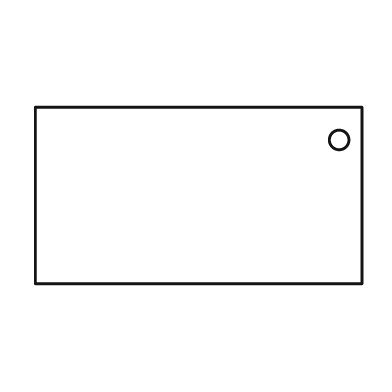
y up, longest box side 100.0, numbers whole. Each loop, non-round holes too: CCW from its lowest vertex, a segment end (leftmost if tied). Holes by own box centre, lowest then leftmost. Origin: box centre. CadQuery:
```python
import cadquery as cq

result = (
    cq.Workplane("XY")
    .moveTo(-50.0, -27.0)
    .lineTo(50.0, -27.0)
    .lineTo(50.0, 27.0)
    .lineTo(-50.0, 27.0)
    .close()
    .moveTo(43.0, 17.0)
    .circle(3.0)
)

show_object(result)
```